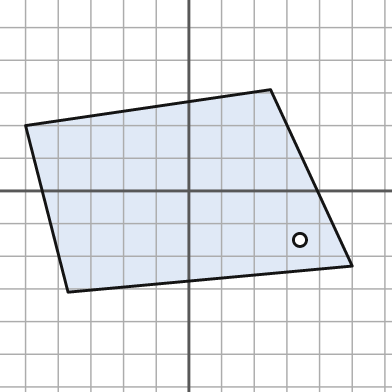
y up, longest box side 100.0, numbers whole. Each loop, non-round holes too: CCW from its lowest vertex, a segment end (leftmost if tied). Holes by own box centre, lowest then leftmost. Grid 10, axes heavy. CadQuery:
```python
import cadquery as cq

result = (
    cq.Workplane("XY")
    .moveTo(-37.0, -31.0)
    .lineTo(50.0, -23.0)
    .lineTo(25.0, 31.0)
    .lineTo(-50.0, 20.0)
    .close()
    .moveTo(34.0, -15.0)
    .circle(2.0)
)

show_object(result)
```